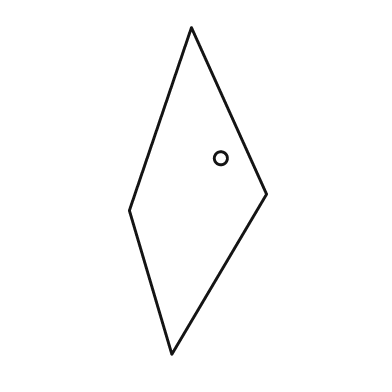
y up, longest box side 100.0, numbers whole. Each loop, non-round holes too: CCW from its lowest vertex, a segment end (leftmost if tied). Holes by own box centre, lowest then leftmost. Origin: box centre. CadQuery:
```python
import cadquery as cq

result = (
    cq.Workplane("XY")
    .moveTo(-8.0, -50.0)
    .lineTo(21.0, -1.0)
    .lineTo(-2.0, 50.0)
    .lineTo(-21.0, -6.0)
    .close()
    .moveTo(7.0, 10.0)
    .circle(2.0)
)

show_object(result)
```